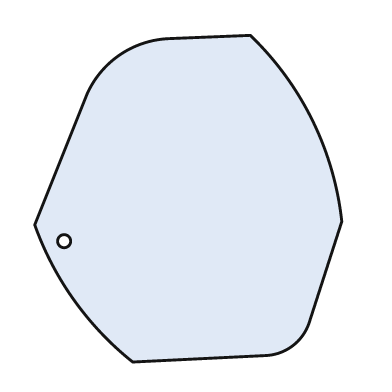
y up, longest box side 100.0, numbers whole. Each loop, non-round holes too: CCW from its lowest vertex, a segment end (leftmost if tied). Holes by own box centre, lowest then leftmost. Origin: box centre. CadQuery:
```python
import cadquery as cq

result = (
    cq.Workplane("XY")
    .moveTo(-17.0, -50.0)
    .lineTo(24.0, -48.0)
    .threePointArc((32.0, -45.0), (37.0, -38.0))
    .lineTo(47.0, -7.0)
    .threePointArc((38.0, 24.0), (19.0, 50.0))
    .lineTo(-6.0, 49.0)
    .threePointArc((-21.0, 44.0), (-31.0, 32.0))
    .lineTo(-47.0, -8.0)
    .threePointArc((-35.0, -31.0), (-17.0, -50.0))
    .close()
    .moveTo(-38.0, -13.0)
    .circle(2.0)
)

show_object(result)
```